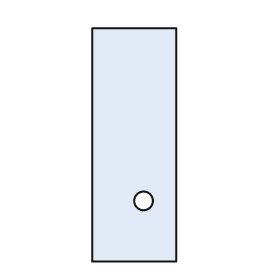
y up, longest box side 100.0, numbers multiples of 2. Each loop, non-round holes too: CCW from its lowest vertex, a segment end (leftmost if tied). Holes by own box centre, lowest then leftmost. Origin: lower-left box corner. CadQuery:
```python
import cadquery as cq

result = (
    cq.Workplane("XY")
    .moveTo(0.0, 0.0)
    .lineTo(36.0, 0.0)
    .lineTo(36.0, 100.0)
    .lineTo(0.0, 100.0)
    .close()
    .moveTo(22.0, 26.0)
    .circle(4.0)
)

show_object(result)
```